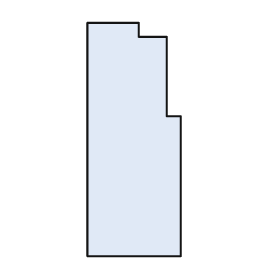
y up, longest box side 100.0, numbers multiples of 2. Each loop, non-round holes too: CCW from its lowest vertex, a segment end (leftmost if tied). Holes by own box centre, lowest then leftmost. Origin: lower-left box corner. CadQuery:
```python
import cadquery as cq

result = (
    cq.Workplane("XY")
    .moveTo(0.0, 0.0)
    .lineTo(40.0, 0.0)
    .lineTo(40.0, 60.0)
    .lineTo(34.0, 60.0)
    .lineTo(34.0, 94.0)
    .lineTo(22.0, 94.0)
    .lineTo(22.0, 100.0)
    .lineTo(0.0, 100.0)
    .close()
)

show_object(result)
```